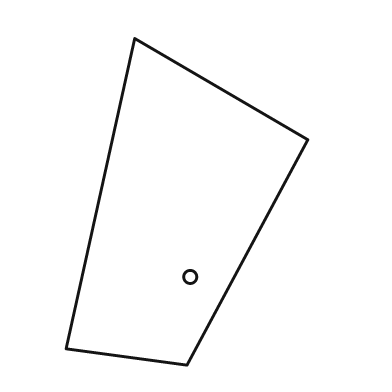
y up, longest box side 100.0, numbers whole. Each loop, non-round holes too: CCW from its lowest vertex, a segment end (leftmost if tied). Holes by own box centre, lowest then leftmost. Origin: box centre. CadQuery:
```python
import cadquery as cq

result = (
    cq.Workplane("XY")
    .moveTo(0.0, -50.0)
    .lineTo(37.0, 19.0)
    .lineTo(-16.0, 50.0)
    .lineTo(-37.0, -45.0)
    .close()
    .moveTo(1.0, -23.0)
    .circle(2.0)
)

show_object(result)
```